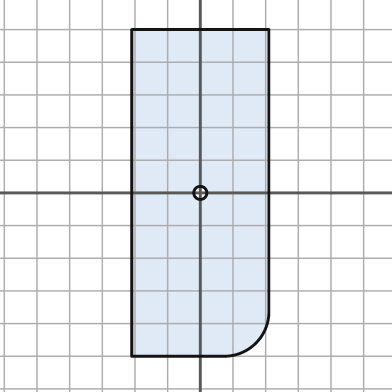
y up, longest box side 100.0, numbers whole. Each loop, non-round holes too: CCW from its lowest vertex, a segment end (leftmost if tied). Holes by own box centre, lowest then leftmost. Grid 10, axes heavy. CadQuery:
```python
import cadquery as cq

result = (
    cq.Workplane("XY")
    .moveTo(-21.0, -50.0)
    .lineTo(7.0, -50.0)
    .threePointArc((17.0, -46.0), (21.0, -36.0))
    .lineTo(21.0, 50.0)
    .lineTo(-21.0, 50.0)
    .close()
    .moveTo(0.0, 0.0)
    .circle(2.0)
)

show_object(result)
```